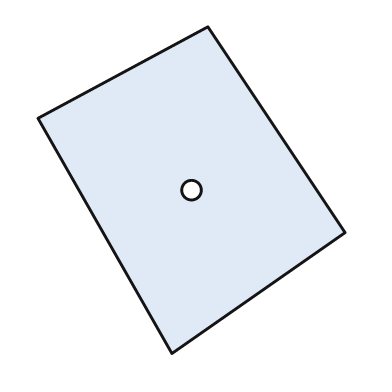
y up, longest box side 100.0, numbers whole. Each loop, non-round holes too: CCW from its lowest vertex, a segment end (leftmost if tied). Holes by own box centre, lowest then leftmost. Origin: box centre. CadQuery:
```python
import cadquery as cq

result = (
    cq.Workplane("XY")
    .moveTo(-6.0, -50.0)
    .lineTo(47.0, -13.0)
    .lineTo(5.0, 50.0)
    .lineTo(-47.0, 22.0)
    .close()
    .moveTo(0.0, 0.0)
    .circle(3.0)
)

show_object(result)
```